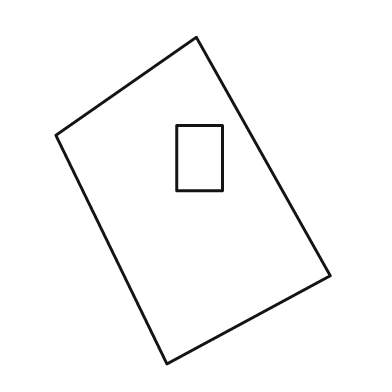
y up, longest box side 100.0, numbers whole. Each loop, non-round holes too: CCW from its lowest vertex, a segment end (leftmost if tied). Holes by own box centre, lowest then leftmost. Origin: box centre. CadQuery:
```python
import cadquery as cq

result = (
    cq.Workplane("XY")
    .moveTo(-8.0, -50.0)
    .lineTo(42.0, -23.0)
    .lineTo(1.0, 50.0)
    .lineTo(-42.0, 20.0)
    .close()
    .moveTo(-5.0, 3.0)
    .lineTo(9.0, 3.0)
    .lineTo(9.0, 23.0)
    .lineTo(-5.0, 23.0)
    .close()
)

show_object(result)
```